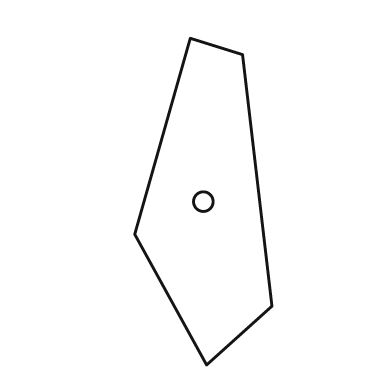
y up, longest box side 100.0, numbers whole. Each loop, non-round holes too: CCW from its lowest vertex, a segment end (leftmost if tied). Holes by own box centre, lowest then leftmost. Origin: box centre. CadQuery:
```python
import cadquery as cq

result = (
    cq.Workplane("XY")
    .moveTo(1.0, -50.0)
    .lineTo(21.0, -32.0)
    .lineTo(12.0, 45.0)
    .lineTo(-4.0, 50.0)
    .lineTo(-21.0, -10.0)
    .close()
    .moveTo(0.0, 0.0)
    .circle(3.0)
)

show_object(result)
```